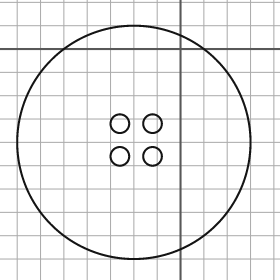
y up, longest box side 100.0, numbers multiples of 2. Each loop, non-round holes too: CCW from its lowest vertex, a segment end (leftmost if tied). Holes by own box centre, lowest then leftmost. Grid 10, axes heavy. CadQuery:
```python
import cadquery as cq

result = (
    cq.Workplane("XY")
    .moveTo(-20.0, -40.0)
    .circle(50.0)
    .moveTo(-26.0, -46.0)
    .circle(4.0)
    .moveTo(-12.0, -46.0)
    .circle(4.0)
    .moveTo(-26.0, -32.0)
    .circle(4.0)
    .moveTo(-12.0, -32.0)
    .circle(4.0)
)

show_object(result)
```